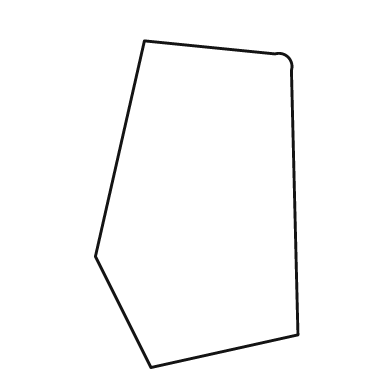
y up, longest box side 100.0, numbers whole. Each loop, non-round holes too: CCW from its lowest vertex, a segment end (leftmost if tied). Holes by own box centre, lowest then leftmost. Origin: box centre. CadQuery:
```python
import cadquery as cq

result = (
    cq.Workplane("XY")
    .moveTo(-14.0, -50.0)
    .lineTo(31.0, -40.0)
    .lineTo(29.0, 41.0)
    .threePointArc((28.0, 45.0), (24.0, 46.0))
    .lineTo(-16.0, 50.0)
    .lineTo(-31.0, -16.0)
    .close()
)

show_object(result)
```